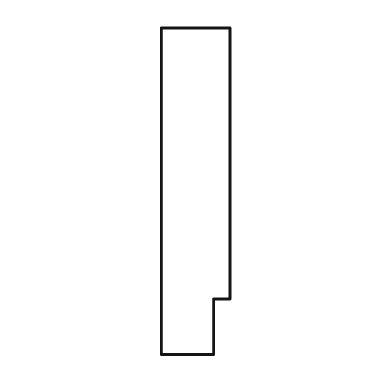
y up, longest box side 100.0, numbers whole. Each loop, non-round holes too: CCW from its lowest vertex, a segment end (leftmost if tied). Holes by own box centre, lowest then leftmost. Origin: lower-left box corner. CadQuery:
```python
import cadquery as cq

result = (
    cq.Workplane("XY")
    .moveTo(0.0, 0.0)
    .lineTo(16.0, 0.0)
    .lineTo(16.0, 17.0)
    .lineTo(21.0, 17.0)
    .lineTo(21.0, 100.0)
    .lineTo(0.0, 100.0)
    .close()
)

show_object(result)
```